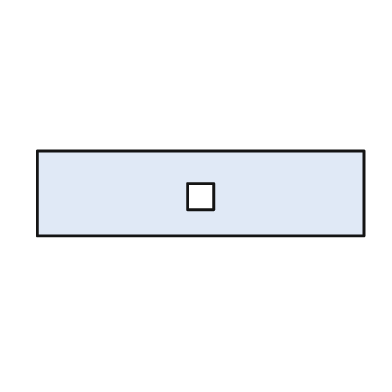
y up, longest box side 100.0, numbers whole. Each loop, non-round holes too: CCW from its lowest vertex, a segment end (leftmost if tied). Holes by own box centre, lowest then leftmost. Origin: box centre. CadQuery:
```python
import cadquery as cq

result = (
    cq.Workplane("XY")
    .moveTo(-50.0, -13.0)
    .lineTo(50.0, -13.0)
    .lineTo(50.0, 13.0)
    .lineTo(-50.0, 13.0)
    .close()
    .moveTo(-4.0, -5.0)
    .lineTo(4.0, -5.0)
    .lineTo(4.0, 3.0)
    .lineTo(-4.0, 3.0)
    .close()
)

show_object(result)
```